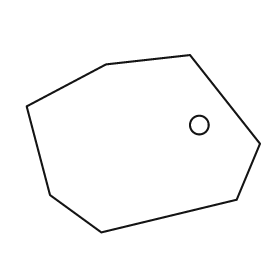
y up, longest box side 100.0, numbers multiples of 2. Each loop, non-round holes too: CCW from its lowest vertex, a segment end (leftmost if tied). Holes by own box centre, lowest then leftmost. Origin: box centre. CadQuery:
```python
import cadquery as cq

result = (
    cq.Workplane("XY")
    .moveTo(-18.0, -38.0)
    .lineTo(40.0, -24.0)
    .lineTo(50.0, 0.0)
    .lineTo(20.0, 38.0)
    .lineTo(-16.0, 34.0)
    .lineTo(-50.0, 16.0)
    .lineTo(-40.0, -22.0)
    .close()
    .moveTo(24.0, 8.0)
    .circle(4.0)
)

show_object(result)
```